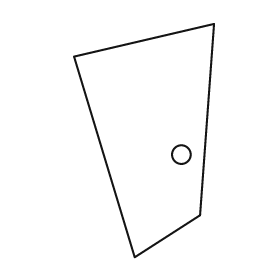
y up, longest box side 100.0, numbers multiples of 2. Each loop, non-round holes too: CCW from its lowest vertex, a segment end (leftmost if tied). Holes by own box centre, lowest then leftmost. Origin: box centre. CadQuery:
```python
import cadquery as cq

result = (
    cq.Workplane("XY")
    .moveTo(-4.0, -50.0)
    .lineTo(24.0, -32.0)
    .lineTo(30.0, 50.0)
    .lineTo(-30.0, 36.0)
    .close()
    .moveTo(16.0, -6.0)
    .circle(4.0)
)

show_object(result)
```